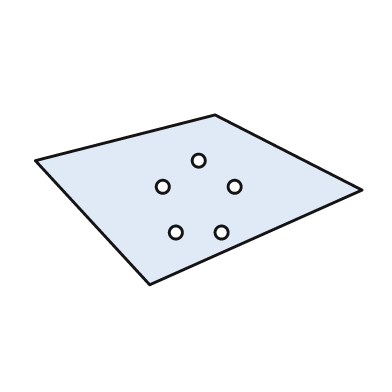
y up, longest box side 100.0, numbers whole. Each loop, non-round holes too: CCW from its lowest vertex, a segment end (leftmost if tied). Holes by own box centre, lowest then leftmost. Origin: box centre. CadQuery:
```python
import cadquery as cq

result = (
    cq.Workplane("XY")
    .moveTo(-15.0, -26.0)
    .lineTo(50.0, 3.0)
    .lineTo(5.0, 26.0)
    .lineTo(-50.0, 12.0)
    .close()
    .moveTo(-7.0, -10.0)
    .circle(2.0)
    .moveTo(7.0, -10.0)
    .circle(2.0)
    .moveTo(-11.0, 4.0)
    .circle(2.0)
    .moveTo(11.0, 4.0)
    .circle(2.0)
    .moveTo(0.0, 12.0)
    .circle(2.0)
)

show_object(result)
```